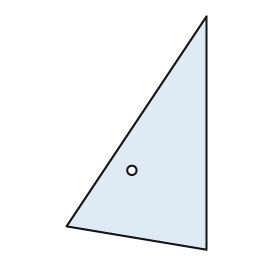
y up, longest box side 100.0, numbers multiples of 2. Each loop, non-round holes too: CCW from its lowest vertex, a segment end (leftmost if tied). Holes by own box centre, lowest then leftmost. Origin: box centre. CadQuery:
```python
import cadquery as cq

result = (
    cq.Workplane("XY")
    .moveTo(30.0, -50.0)
    .lineTo(30.0, 50.0)
    .lineTo(-30.0, -40.0)
    .close()
    .moveTo(-2.0, -16.0)
    .circle(2.0)
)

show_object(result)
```